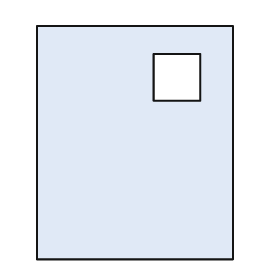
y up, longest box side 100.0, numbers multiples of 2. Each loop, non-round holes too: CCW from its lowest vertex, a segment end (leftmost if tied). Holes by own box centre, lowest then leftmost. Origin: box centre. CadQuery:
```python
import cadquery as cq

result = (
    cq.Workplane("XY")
    .moveTo(-42.0, -50.0)
    .lineTo(42.0, -50.0)
    .lineTo(42.0, 50.0)
    .lineTo(-42.0, 50.0)
    .close()
    .moveTo(8.0, 18.0)
    .lineTo(28.0, 18.0)
    .lineTo(28.0, 38.0)
    .lineTo(8.0, 38.0)
    .close()
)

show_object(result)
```